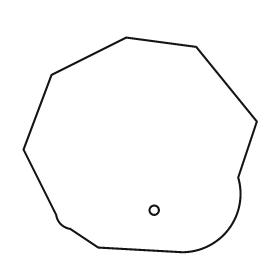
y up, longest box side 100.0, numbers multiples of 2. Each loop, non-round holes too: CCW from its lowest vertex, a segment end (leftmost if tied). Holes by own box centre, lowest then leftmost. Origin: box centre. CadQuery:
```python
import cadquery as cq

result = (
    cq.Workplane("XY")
    .moveTo(18.0, -46.0)
    .threePointArc((38.0, -36.0), (42.0, -14.0))
    .lineTo(50.0, 10.0)
    .lineTo(24.0, 42.0)
    .lineTo(-6.0, 46.0)
    .lineTo(-38.0, 30.0)
    .lineTo(-50.0, -2.0)
    .lineTo(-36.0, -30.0)
    .threePointArc((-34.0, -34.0), (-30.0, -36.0))
    .lineTo(-18.0, -44.0)
    .close()
    .moveTo(6.0, -28.0)
    .circle(2.0)
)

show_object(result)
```